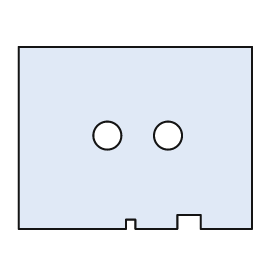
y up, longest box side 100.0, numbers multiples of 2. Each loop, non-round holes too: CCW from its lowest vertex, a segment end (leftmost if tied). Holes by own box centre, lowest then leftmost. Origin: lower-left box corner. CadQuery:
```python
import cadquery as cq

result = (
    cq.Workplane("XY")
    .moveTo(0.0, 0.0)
    .lineTo(46.0, 0.0)
    .lineTo(46.0, 4.0)
    .lineTo(50.0, 4.0)
    .lineTo(50.0, 0.0)
    .lineTo(68.0, 0.0)
    .lineTo(68.0, 6.0)
    .lineTo(78.0, 6.0)
    .lineTo(78.0, 0.0)
    .lineTo(100.0, 0.0)
    .lineTo(100.0, 78.0)
    .lineTo(0.0, 78.0)
    .close()
    .moveTo(38.0, 40.0)
    .circle(6.0)
    .moveTo(64.0, 40.0)
    .circle(6.0)
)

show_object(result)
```